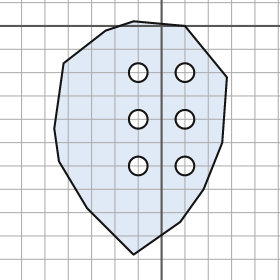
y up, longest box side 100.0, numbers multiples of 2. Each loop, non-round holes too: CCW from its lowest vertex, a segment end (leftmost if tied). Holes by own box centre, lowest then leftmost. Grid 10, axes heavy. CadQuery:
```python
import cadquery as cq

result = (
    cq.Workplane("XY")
    .moveTo(-12.0, -98.0)
    .lineTo(8.0, -84.0)
    .lineTo(18.0, -70.0)
    .lineTo(26.0, -50.0)
    .lineTo(28.0, -22.0)
    .lineTo(10.0, 0.0)
    .lineTo(-12.0, 2.0)
    .lineTo(-24.0, -2.0)
    .lineTo(-42.0, -16.0)
    .lineTo(-46.0, -44.0)
    .lineTo(-44.0, -58.0)
    .lineTo(-32.0, -78.0)
    .close()
    .moveTo(-10.0, -60.0)
    .circle(4.0)
    .moveTo(10.0, -60.0)
    .circle(4.0)
    .moveTo(-10.0, -40.0)
    .circle(4.0)
    .moveTo(10.0, -40.0)
    .circle(4.0)
    .moveTo(-10.0, -20.0)
    .circle(4.0)
    .moveTo(10.0, -20.0)
    .circle(4.0)
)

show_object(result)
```